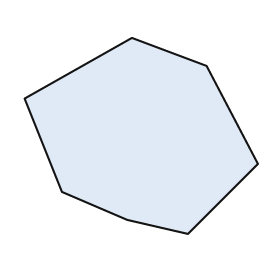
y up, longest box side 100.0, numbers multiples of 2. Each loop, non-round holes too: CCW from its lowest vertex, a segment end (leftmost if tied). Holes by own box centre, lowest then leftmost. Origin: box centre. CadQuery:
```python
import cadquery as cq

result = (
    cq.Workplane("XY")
    .moveTo(20.0, -42.0)
    .lineTo(50.0, -12.0)
    .lineTo(28.0, 30.0)
    .lineTo(-4.0, 42.0)
    .lineTo(-50.0, 16.0)
    .lineTo(-34.0, -24.0)
    .lineTo(-6.0, -36.0)
    .close()
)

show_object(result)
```